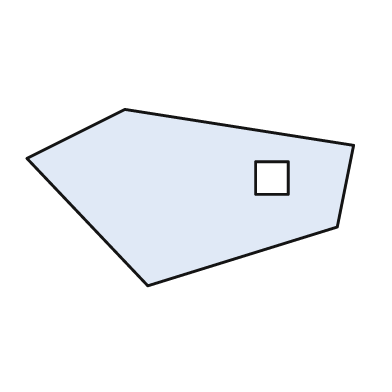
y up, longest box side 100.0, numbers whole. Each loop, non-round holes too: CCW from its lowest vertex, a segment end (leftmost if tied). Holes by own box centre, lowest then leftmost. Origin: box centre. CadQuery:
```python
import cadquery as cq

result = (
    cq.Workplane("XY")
    .moveTo(-13.0, -27.0)
    .lineTo(45.0, -9.0)
    .lineTo(50.0, 16.0)
    .lineTo(-20.0, 27.0)
    .lineTo(-50.0, 12.0)
    .close()
    .moveTo(20.0, 1.0)
    .lineTo(30.0, 1.0)
    .lineTo(30.0, 11.0)
    .lineTo(20.0, 11.0)
    .close()
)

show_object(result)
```